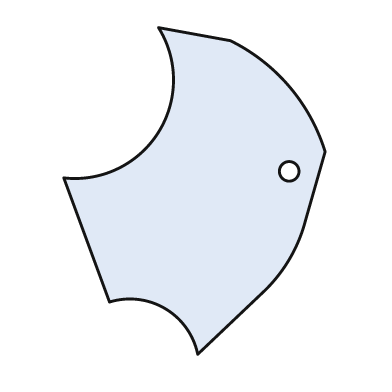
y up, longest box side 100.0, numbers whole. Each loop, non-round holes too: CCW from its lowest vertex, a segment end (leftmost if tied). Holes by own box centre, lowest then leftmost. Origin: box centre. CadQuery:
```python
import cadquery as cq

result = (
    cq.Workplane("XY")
    .moveTo(1.0, -50.0)
    .lineTo(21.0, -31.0)
    .threePointArc((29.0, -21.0), (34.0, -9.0))
    .lineTo(40.0, 12.0)
    .threePointArc((29.0, 32.0), (11.0, 46.0))
    .lineTo(-11.0, 50.0)
    .threePointArc((-11.0, 18.0), (-40.0, 4.0))
    .lineTo(-26.0, -34.0)
    .threePointArc((-9.0, -36.0), (1.0, -50.0))
    .close()
    .moveTo(29.0, 6.0)
    .circle(3.0)
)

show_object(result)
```